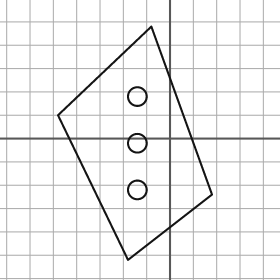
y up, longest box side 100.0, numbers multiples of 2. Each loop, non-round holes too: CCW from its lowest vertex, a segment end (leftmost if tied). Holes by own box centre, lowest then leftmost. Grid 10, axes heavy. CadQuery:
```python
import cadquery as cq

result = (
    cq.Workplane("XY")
    .moveTo(-18.0, -52.0)
    .lineTo(18.0, -24.0)
    .lineTo(-8.0, 48.0)
    .lineTo(-48.0, 10.0)
    .close()
    .moveTo(-14.0, -22.0)
    .circle(4.0)
    .moveTo(-14.0, -2.0)
    .circle(4.0)
    .moveTo(-14.0, 18.0)
    .circle(4.0)
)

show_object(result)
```